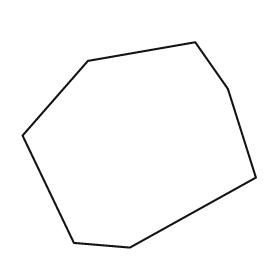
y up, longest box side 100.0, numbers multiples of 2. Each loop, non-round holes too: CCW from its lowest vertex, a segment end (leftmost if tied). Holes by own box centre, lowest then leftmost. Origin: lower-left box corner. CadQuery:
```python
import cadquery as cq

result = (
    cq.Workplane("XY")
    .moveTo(46.0, 0.0)
    .lineTo(100.0, 30.0)
    .lineTo(88.0, 68.0)
    .lineTo(74.0, 88.0)
    .lineTo(28.0, 80.0)
    .lineTo(0.0, 48.0)
    .lineTo(22.0, 2.0)
    .close()
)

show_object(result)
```